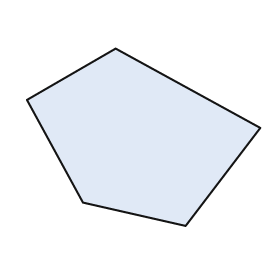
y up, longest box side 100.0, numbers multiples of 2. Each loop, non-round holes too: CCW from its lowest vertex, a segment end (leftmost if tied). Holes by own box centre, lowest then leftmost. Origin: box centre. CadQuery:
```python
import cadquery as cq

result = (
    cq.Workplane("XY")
    .moveTo(18.0, -38.0)
    .lineTo(50.0, 4.0)
    .lineTo(-12.0, 38.0)
    .lineTo(-50.0, 16.0)
    .lineTo(-26.0, -28.0)
    .close()
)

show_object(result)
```